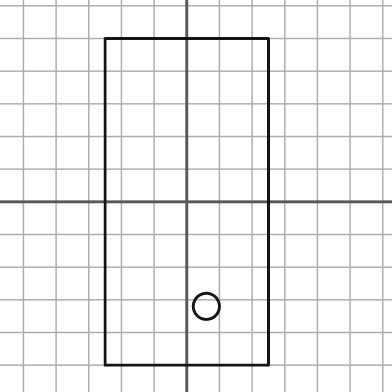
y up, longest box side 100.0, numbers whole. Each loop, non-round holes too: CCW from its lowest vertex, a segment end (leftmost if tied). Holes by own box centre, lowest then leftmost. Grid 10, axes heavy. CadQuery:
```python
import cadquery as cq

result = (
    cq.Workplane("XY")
    .moveTo(-25.0, -50.0)
    .lineTo(25.0, -50.0)
    .lineTo(25.0, 50.0)
    .lineTo(-25.0, 50.0)
    .close()
    .moveTo(6.0, -32.0)
    .circle(4.0)
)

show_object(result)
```